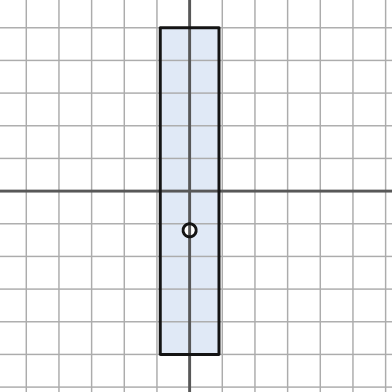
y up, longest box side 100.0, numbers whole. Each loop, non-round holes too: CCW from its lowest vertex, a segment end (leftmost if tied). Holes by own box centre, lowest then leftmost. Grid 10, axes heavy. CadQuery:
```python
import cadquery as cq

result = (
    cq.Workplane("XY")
    .moveTo(-9.0, -50.0)
    .lineTo(9.0, -50.0)
    .lineTo(9.0, 50.0)
    .lineTo(-9.0, 50.0)
    .close()
    .moveTo(0.0, -12.0)
    .circle(2.0)
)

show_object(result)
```